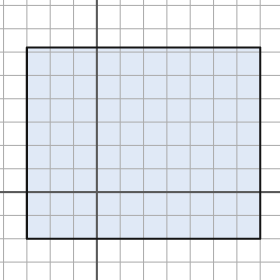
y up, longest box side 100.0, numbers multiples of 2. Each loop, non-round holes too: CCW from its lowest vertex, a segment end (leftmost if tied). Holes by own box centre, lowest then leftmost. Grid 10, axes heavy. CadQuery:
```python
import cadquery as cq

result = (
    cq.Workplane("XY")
    .moveTo(-30.0, -20.0)
    .lineTo(70.0, -20.0)
    .lineTo(70.0, 62.0)
    .lineTo(-30.0, 62.0)
    .close()
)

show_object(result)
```